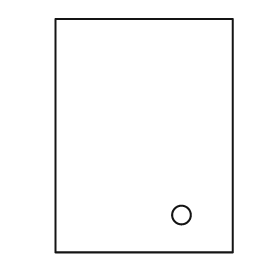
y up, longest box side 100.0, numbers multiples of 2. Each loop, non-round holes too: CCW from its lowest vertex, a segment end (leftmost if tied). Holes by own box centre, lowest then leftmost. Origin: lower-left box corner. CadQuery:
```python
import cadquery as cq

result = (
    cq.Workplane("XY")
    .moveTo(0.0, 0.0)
    .lineTo(76.0, 0.0)
    .lineTo(76.0, 100.0)
    .lineTo(0.0, 100.0)
    .close()
    .moveTo(54.0, 16.0)
    .circle(4.0)
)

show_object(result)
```